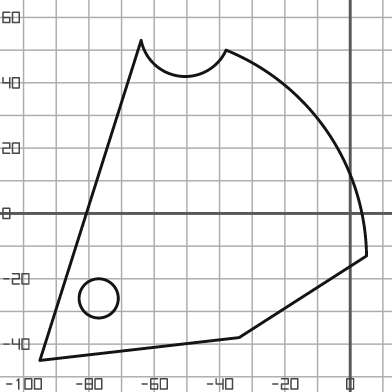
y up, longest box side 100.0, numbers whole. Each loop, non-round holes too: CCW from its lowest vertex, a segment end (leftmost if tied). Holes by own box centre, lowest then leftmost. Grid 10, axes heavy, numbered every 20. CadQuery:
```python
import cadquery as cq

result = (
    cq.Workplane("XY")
    .moveTo(-95.0, -45.0)
    .lineTo(-34.0, -38.0)
    .lineTo(5.0, -13.0)
    .threePointArc((-7.0, 25.0), (-38.0, 50.0))
    .threePointArc((-52.0, 42.0), (-64.0, 53.0))
    .close()
    .moveTo(-77.0, -26.0)
    .circle(6.0)
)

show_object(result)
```